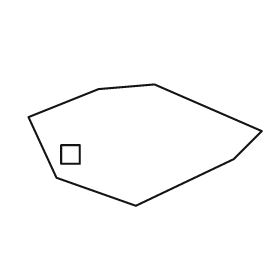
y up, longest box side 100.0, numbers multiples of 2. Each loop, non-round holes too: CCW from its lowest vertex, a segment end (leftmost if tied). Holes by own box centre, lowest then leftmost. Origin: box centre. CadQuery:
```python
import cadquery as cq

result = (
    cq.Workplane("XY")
    .moveTo(-4.0, -26.0)
    .lineTo(38.0, -6.0)
    .lineTo(50.0, 6.0)
    .lineTo(4.0, 26.0)
    .lineTo(-20.0, 24.0)
    .lineTo(-50.0, 12.0)
    .lineTo(-38.0, -14.0)
    .close()
    .moveTo(-36.0, -8.0)
    .lineTo(-28.0, -8.0)
    .lineTo(-28.0, 0.0)
    .lineTo(-36.0, 0.0)
    .close()
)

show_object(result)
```